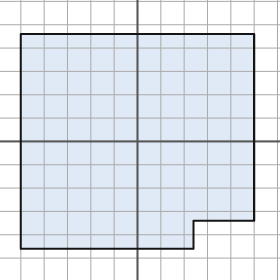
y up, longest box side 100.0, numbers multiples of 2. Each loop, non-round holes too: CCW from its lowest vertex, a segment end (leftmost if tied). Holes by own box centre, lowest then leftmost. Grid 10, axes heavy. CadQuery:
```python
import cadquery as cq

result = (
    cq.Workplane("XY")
    .moveTo(-50.0, -46.0)
    .lineTo(24.0, -46.0)
    .lineTo(24.0, -34.0)
    .lineTo(50.0, -34.0)
    .lineTo(50.0, 46.0)
    .lineTo(-50.0, 46.0)
    .close()
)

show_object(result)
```